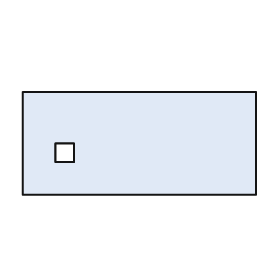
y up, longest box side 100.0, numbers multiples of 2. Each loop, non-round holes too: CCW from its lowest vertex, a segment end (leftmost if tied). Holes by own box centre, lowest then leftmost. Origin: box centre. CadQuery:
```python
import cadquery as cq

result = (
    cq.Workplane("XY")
    .moveTo(-50.0, -22.0)
    .lineTo(50.0, -22.0)
    .lineTo(50.0, 22.0)
    .lineTo(-50.0, 22.0)
    .close()
    .moveTo(-36.0, -8.0)
    .lineTo(-28.0, -8.0)
    .lineTo(-28.0, 0.0)
    .lineTo(-36.0, 0.0)
    .close()
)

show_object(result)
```